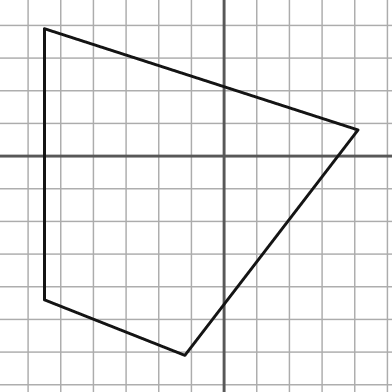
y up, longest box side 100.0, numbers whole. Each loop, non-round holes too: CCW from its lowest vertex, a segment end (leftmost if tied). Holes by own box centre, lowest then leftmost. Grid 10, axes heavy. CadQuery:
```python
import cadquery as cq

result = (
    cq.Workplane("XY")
    .moveTo(-12.0, -61.0)
    .lineTo(41.0, 8.0)
    .lineTo(-55.0, 39.0)
    .lineTo(-55.0, -44.0)
    .close()
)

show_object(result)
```